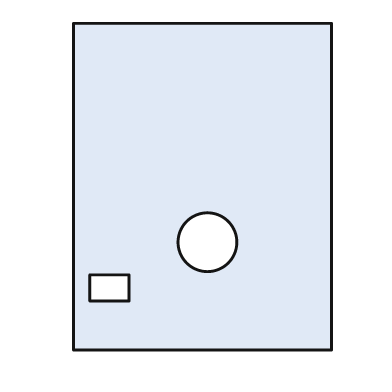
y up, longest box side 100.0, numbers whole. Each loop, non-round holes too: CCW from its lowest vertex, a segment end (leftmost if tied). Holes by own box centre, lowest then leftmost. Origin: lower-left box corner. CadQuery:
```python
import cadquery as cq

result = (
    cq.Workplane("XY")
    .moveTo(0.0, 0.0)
    .lineTo(79.0, 0.0)
    .lineTo(79.0, 100.0)
    .lineTo(0.0, 100.0)
    .close()
    .moveTo(5.0, 15.0)
    .lineTo(17.0, 15.0)
    .lineTo(17.0, 23.0)
    .lineTo(5.0, 23.0)
    .close()
    .moveTo(41.0, 33.0)
    .circle(9.0)
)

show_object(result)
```